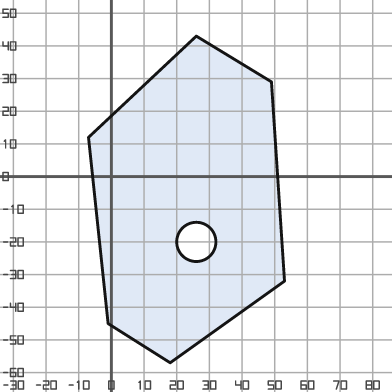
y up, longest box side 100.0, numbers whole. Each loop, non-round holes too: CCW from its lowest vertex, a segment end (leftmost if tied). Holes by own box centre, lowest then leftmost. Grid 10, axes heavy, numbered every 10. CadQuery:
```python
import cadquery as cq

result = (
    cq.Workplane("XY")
    .moveTo(18.0, -57.0)
    .lineTo(53.0, -32.0)
    .lineTo(49.0, 29.0)
    .lineTo(26.0, 43.0)
    .lineTo(-7.0, 12.0)
    .lineTo(-1.0, -45.0)
    .close()
    .moveTo(26.0, -20.0)
    .circle(6.0)
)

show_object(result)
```